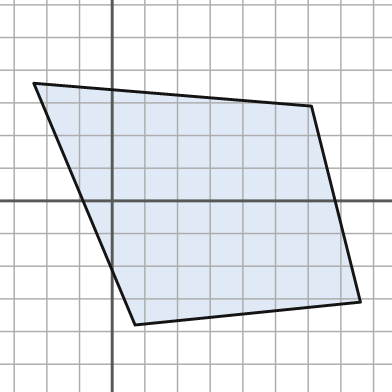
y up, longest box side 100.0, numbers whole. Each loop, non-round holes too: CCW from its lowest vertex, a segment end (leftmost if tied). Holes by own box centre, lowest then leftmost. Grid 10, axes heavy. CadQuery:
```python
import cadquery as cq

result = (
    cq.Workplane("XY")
    .moveTo(7.0, -38.0)
    .lineTo(76.0, -31.0)
    .lineTo(61.0, 29.0)
    .lineTo(-24.0, 36.0)
    .close()
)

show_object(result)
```